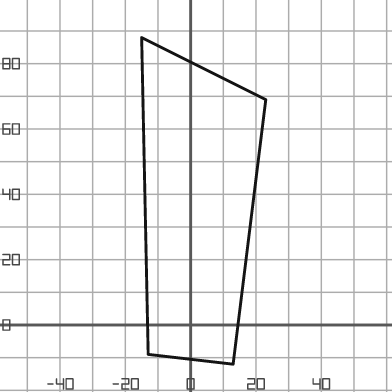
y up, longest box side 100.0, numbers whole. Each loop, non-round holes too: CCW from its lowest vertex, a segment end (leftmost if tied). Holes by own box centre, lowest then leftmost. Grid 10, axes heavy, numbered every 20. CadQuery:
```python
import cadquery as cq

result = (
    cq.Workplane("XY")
    .moveTo(13.0, -12.0)
    .lineTo(23.0, 69.0)
    .lineTo(-15.0, 88.0)
    .lineTo(-13.0, -9.0)
    .close()
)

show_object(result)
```